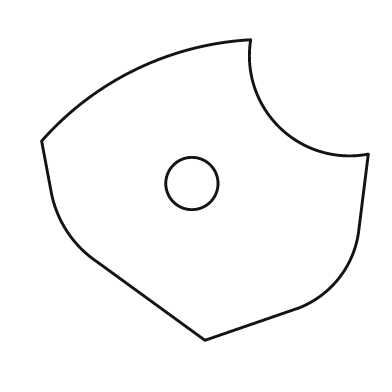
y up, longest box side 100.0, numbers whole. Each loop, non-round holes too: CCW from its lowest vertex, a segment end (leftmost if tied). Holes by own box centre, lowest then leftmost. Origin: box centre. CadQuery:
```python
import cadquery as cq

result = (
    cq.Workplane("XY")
    .moveTo(0.0, -46.0)
    .lineTo(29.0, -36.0)
    .threePointArc((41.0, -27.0), (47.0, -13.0))
    .lineTo(50.0, 11.0)
    .threePointArc((23.0, 19.0), (14.0, 46.0))
    .threePointArc((-21.0, 37.0), (-50.0, 15.0))
    .lineTo(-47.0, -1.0)
    .threePointArc((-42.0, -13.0), (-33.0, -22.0))
    .close()
    .moveTo(-4.0, 2.0)
    .circle(8.0)
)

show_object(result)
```